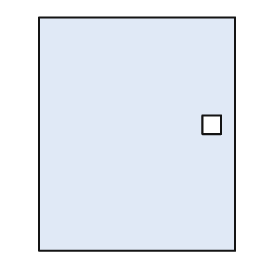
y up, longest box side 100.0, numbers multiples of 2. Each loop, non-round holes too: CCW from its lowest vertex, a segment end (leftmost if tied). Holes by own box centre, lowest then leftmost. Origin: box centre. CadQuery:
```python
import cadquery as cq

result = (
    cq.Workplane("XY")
    .moveTo(-42.0, -50.0)
    .lineTo(42.0, -50.0)
    .lineTo(42.0, 50.0)
    .lineTo(-42.0, 50.0)
    .close()
    .moveTo(28.0, 0.0)
    .lineTo(36.0, 0.0)
    .lineTo(36.0, 8.0)
    .lineTo(28.0, 8.0)
    .close()
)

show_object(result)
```